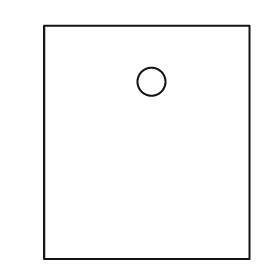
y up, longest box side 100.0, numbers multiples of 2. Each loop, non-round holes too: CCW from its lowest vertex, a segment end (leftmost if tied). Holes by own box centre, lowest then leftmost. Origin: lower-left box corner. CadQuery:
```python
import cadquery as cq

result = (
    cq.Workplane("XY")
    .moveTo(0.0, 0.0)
    .lineTo(88.0, 0.0)
    .lineTo(88.0, 100.0)
    .lineTo(0.0, 100.0)
    .close()
    .moveTo(46.0, 76.0)
    .circle(6.0)
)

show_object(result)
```